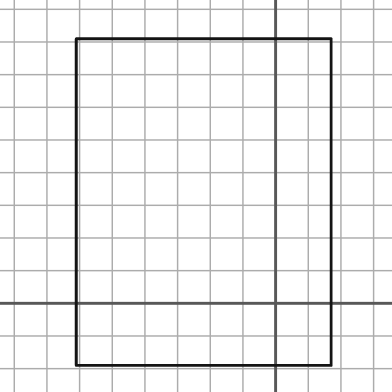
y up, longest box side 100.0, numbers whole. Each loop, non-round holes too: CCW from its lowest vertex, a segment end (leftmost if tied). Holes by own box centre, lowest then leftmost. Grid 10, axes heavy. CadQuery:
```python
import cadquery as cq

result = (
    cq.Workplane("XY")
    .moveTo(-61.0, -19.0)
    .lineTo(17.0, -19.0)
    .lineTo(17.0, 81.0)
    .lineTo(-61.0, 81.0)
    .close()
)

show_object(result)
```